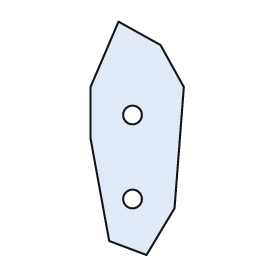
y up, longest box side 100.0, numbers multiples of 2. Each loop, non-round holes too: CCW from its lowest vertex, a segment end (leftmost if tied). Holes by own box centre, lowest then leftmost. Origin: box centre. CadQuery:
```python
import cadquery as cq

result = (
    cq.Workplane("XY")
    .moveTo(4.0, -50.0)
    .lineTo(16.0, -30.0)
    .lineTo(20.0, 22.0)
    .lineTo(10.0, 40.0)
    .lineTo(-8.0, 50.0)
    .lineTo(-20.0, 22.0)
    .lineTo(-20.0, 0.0)
    .lineTo(-12.0, -44.0)
    .close()
    .moveTo(-2.0, -26.0)
    .circle(4.0)
    .moveTo(-2.0, 10.0)
    .circle(4.0)
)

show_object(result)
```